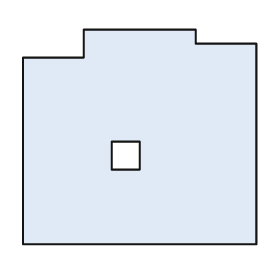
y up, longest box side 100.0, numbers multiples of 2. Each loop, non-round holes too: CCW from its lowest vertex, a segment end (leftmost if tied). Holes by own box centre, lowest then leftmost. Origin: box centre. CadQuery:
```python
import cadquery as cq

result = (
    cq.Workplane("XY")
    .moveTo(-50.0, -46.0)
    .lineTo(50.0, -46.0)
    .lineTo(50.0, 40.0)
    .lineTo(24.0, 40.0)
    .lineTo(24.0, 46.0)
    .lineTo(-24.0, 46.0)
    .lineTo(-24.0, 34.0)
    .lineTo(-50.0, 34.0)
    .close()
    .moveTo(-12.0, -14.0)
    .lineTo(0.0, -14.0)
    .lineTo(0.0, -2.0)
    .lineTo(-12.0, -2.0)
    .close()
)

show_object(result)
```